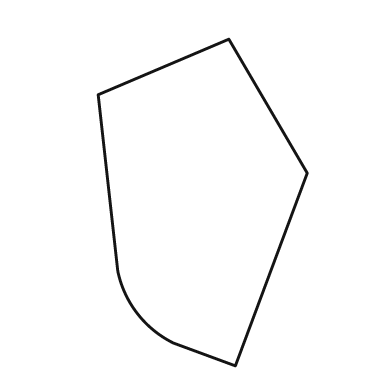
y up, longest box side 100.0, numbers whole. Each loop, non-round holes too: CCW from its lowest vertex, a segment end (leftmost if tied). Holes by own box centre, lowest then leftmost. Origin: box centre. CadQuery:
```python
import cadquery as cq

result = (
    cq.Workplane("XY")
    .moveTo(10.0, -50.0)
    .lineTo(32.0, 9.0)
    .lineTo(8.0, 50.0)
    .lineTo(-32.0, 33.0)
    .lineTo(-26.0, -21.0)
    .threePointArc((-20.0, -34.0), (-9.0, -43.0))
    .close()
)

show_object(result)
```